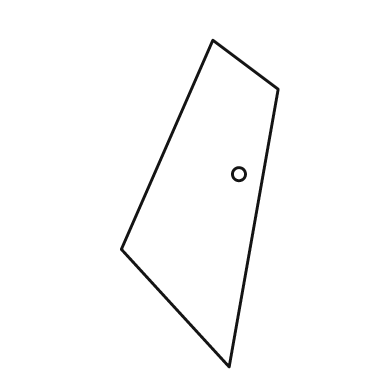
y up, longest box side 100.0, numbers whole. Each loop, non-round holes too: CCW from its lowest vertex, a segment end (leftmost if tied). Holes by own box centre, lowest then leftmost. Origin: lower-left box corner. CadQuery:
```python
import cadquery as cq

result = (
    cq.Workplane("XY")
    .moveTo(33.0, 0.0)
    .lineTo(48.0, 85.0)
    .lineTo(28.0, 100.0)
    .lineTo(0.0, 36.0)
    .close()
    .moveTo(36.0, 59.0)
    .circle(2.0)
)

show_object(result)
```